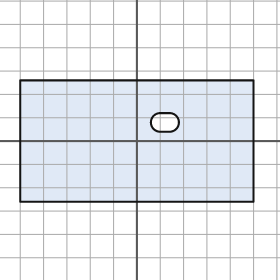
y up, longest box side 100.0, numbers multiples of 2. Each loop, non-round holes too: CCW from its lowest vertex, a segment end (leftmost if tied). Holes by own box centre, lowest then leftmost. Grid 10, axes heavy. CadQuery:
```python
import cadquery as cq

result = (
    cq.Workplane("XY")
    .moveTo(-50.0, -26.0)
    .lineTo(50.0, -26.0)
    .lineTo(50.0, 26.0)
    .lineTo(-50.0, 26.0)
    .close()
    .moveTo(10.0, 4.0)
    .lineTo(14.0, 4.0)
    .threePointArc((18.0, 8.0), (14.0, 12.0))
    .lineTo(10.0, 12.0)
    .threePointArc((6.0, 8.0), (10.0, 4.0))
    .close()
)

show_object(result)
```